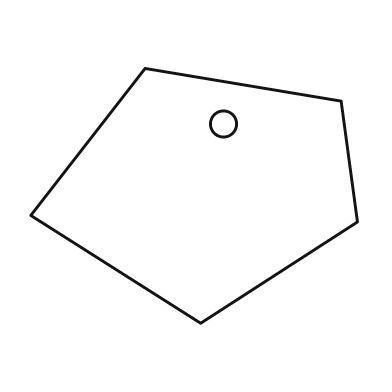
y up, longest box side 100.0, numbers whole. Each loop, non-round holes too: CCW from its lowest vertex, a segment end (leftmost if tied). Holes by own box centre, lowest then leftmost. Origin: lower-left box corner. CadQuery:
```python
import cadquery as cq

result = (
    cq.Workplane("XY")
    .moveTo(52.0, 0.0)
    .lineTo(100.0, 31.0)
    .lineTo(95.0, 68.0)
    .lineTo(35.0, 78.0)
    .lineTo(0.0, 33.0)
    .close()
    .moveTo(59.0, 61.0)
    .circle(4.0)
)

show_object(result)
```